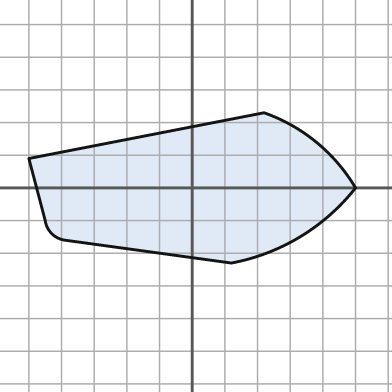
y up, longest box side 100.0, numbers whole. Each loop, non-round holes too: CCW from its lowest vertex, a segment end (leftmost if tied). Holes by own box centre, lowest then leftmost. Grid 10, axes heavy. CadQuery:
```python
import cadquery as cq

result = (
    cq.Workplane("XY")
    .moveTo(12.0, -23.0)
    .threePointArc((33.0, -15.0), (50.0, 0.0))
    .threePointArc((38.0, 14.0), (22.0, 23.0))
    .lineTo(-50.0, 9.0)
    .lineTo(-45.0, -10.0)
    .threePointArc((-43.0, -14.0), (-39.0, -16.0))
    .close()
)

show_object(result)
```